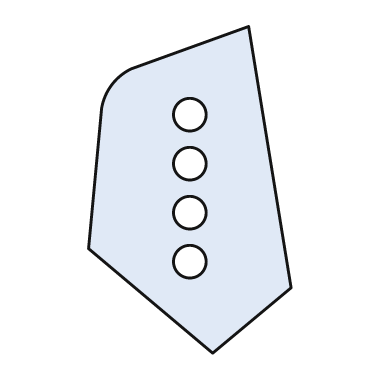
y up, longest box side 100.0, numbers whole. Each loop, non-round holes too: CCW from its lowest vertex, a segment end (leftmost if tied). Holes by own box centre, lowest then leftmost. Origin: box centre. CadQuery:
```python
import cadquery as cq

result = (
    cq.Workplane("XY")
    .moveTo(7.0, -50.0)
    .lineTo(31.0, -30.0)
    .lineTo(18.0, 50.0)
    .lineTo(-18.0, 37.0)
    .threePointArc((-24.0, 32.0), (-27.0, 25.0))
    .lineTo(-31.0, -18.0)
    .close()
    .moveTo(0.0, -22.0)
    .circle(5.0)
    .moveTo(0.0, -7.0)
    .circle(5.0)
    .moveTo(0.0, 8.0)
    .circle(5.0)
    .moveTo(0.0, 23.0)
    .circle(5.0)
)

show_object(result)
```